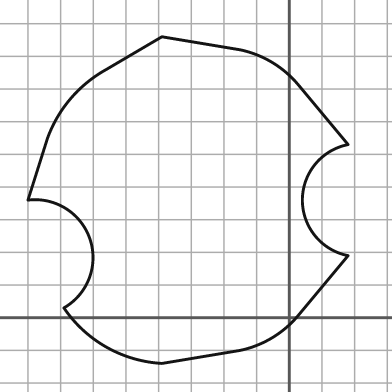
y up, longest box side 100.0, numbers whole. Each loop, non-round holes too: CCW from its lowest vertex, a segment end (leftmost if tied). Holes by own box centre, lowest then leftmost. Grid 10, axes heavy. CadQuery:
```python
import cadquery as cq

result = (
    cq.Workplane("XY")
    .moveTo(-39.0, -14.0)
    .lineTo(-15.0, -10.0)
    .threePointArc((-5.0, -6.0), (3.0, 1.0))
    .lineTo(18.0, 19.0)
    .threePointArc((4.0, 36.0), (18.0, 53.0))
    .lineTo(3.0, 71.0)
    .threePointArc((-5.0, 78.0), (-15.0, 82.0))
    .lineTo(-39.0, 86.0)
    .lineTo(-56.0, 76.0)
    .threePointArc((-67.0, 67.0), (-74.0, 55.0))
    .lineTo(-80.0, 36.0)
    .threePointArc((-61.0, 24.0), (-69.0, 3.0))
    .threePointArc((-56.0, -9.0), (-39.0, -14.0))
    .close()
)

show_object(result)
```